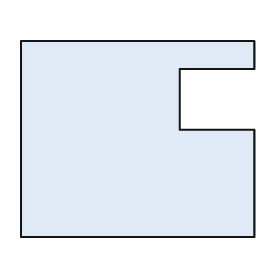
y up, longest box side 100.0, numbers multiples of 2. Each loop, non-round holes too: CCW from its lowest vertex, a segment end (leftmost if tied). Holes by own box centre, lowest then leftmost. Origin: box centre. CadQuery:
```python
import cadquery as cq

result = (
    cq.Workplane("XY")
    .moveTo(-50.0, -42.0)
    .lineTo(50.0, -42.0)
    .lineTo(50.0, 4.0)
    .lineTo(18.0, 4.0)
    .lineTo(18.0, 30.0)
    .lineTo(50.0, 30.0)
    .lineTo(50.0, 42.0)
    .lineTo(-50.0, 42.0)
    .close()
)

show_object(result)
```